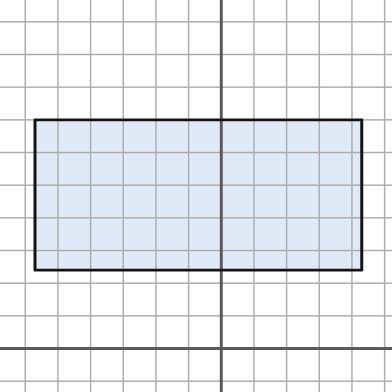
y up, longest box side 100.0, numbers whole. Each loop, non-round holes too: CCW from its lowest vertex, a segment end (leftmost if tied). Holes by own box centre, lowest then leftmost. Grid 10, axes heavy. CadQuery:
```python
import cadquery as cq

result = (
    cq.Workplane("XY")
    .moveTo(-57.0, 24.0)
    .lineTo(43.0, 24.0)
    .lineTo(43.0, 70.0)
    .lineTo(-57.0, 70.0)
    .close()
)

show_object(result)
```